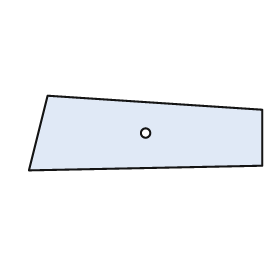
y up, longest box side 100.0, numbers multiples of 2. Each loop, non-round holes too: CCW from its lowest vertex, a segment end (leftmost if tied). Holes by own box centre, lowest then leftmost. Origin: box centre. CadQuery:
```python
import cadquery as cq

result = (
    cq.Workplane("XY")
    .moveTo(-50.0, -16.0)
    .lineTo(50.0, -14.0)
    .lineTo(50.0, 10.0)
    .lineTo(-42.0, 16.0)
    .close()
    .moveTo(0.0, 0.0)
    .circle(2.0)
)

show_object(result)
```